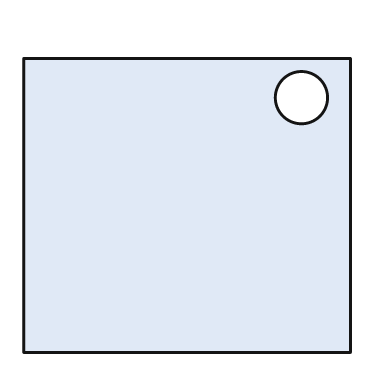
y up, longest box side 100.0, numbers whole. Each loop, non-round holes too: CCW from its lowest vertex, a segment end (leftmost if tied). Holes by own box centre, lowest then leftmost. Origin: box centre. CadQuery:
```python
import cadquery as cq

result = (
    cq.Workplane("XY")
    .moveTo(-50.0, -45.0)
    .lineTo(50.0, -45.0)
    .lineTo(50.0, 45.0)
    .lineTo(-50.0, 45.0)
    .close()
    .moveTo(35.0, 33.0)
    .circle(8.0)
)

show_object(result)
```